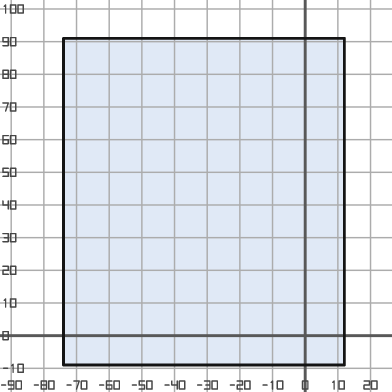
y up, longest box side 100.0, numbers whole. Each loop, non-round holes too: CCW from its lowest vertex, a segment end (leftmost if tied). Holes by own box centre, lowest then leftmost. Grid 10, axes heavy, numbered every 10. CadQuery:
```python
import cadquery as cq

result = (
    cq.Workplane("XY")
    .moveTo(-74.0, -9.0)
    .lineTo(12.0, -9.0)
    .lineTo(12.0, 91.0)
    .lineTo(-74.0, 91.0)
    .close()
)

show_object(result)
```